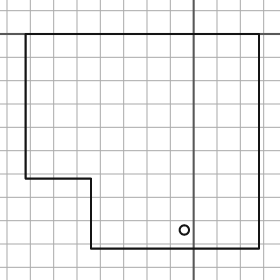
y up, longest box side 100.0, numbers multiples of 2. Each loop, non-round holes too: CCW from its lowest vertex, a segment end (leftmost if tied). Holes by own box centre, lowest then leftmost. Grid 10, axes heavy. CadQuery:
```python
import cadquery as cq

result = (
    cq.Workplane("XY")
    .moveTo(-44.0, -92.0)
    .lineTo(28.0, -92.0)
    .lineTo(28.0, 0.0)
    .lineTo(-72.0, 0.0)
    .lineTo(-72.0, -62.0)
    .lineTo(-44.0, -62.0)
    .close()
    .moveTo(-4.0, -84.0)
    .circle(2.0)
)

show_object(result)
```